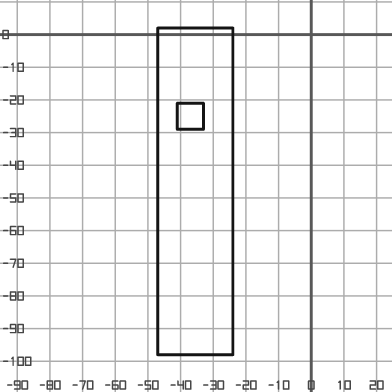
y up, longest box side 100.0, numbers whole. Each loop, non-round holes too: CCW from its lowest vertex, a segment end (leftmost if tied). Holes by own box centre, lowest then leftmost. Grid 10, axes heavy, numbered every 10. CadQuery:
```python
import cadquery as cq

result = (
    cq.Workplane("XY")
    .moveTo(-47.0, -98.0)
    .lineTo(-24.0, -98.0)
    .lineTo(-24.0, 2.0)
    .lineTo(-47.0, 2.0)
    .close()
    .moveTo(-41.0, -29.0)
    .lineTo(-33.0, -29.0)
    .lineTo(-33.0, -21.0)
    .lineTo(-41.0, -21.0)
    .close()
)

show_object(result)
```